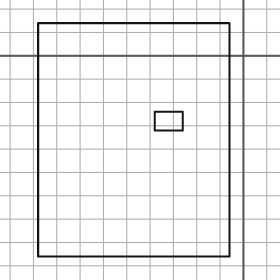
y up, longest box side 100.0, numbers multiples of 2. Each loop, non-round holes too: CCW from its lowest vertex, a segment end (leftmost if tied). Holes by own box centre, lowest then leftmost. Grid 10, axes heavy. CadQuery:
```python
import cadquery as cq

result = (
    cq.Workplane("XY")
    .moveTo(-88.0, -86.0)
    .lineTo(-6.0, -86.0)
    .lineTo(-6.0, 14.0)
    .lineTo(-88.0, 14.0)
    .close()
    .moveTo(-38.0, -32.0)
    .lineTo(-26.0, -32.0)
    .lineTo(-26.0, -24.0)
    .lineTo(-38.0, -24.0)
    .close()
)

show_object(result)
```